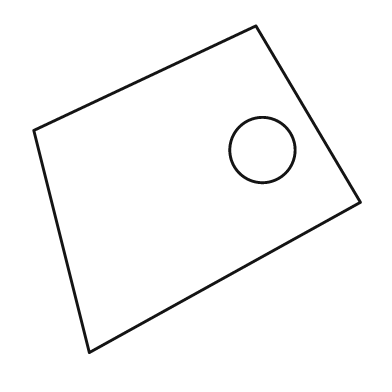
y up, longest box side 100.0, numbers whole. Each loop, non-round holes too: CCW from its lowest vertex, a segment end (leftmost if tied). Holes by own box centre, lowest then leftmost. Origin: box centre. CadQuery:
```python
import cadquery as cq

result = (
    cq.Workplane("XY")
    .moveTo(-33.0, -50.0)
    .lineTo(50.0, -4.0)
    .lineTo(18.0, 50.0)
    .lineTo(-50.0, 18.0)
    .close()
    .moveTo(20.0, 12.0)
    .circle(10.0)
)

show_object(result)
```